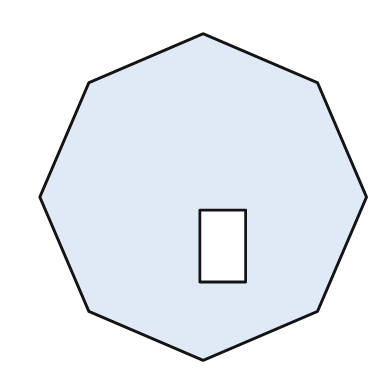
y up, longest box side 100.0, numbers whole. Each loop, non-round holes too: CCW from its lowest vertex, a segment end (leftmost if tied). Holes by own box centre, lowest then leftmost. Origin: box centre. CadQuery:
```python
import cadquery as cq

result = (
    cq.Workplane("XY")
    .moveTo(0.0, -50.0)
    .lineTo(35.0, -35.0)
    .lineTo(50.0, 0.0)
    .lineTo(35.0, 35.0)
    .lineTo(0.0, 50.0)
    .lineTo(-35.0, 35.0)
    .lineTo(-50.0, 0.0)
    .lineTo(-35.0, -35.0)
    .close()
    .moveTo(-1.0, -26.0)
    .lineTo(13.0, -26.0)
    .lineTo(13.0, -4.0)
    .lineTo(-1.0, -4.0)
    .close()
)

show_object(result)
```